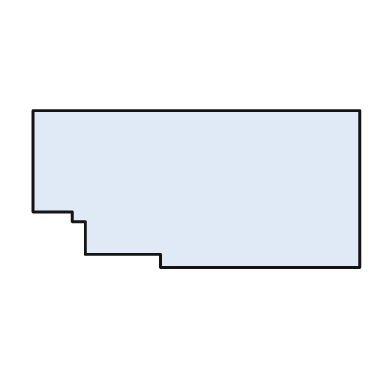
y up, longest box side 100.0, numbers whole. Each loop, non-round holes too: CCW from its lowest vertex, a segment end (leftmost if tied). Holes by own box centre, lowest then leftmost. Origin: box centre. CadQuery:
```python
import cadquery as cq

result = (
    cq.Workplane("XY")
    .moveTo(-11.0, -24.0)
    .lineTo(50.0, -24.0)
    .lineTo(50.0, 24.0)
    .lineTo(-50.0, 24.0)
    .lineTo(-50.0, -7.0)
    .lineTo(-38.0, -7.0)
    .lineTo(-38.0, -10.0)
    .lineTo(-34.0, -10.0)
    .lineTo(-34.0, -20.0)
    .lineTo(-11.0, -20.0)
    .close()
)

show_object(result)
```